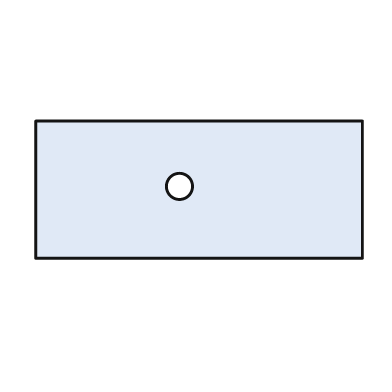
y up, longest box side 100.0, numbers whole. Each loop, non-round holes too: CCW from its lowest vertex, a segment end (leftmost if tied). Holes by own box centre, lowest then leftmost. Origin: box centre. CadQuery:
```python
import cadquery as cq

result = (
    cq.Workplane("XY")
    .moveTo(-50.0, -21.0)
    .lineTo(50.0, -21.0)
    .lineTo(50.0, 21.0)
    .lineTo(-50.0, 21.0)
    .close()
    .moveTo(-6.0, 1.0)
    .circle(4.0)
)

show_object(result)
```